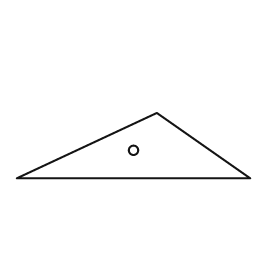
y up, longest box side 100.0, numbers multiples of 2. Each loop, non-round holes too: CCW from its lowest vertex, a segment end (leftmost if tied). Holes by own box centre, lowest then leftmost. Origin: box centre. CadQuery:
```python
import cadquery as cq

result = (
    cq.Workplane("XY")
    .moveTo(-50.0, -14.0)
    .lineTo(50.0, -14.0)
    .lineTo(10.0, 14.0)
    .close()
    .moveTo(0.0, -2.0)
    .circle(2.0)
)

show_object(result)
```